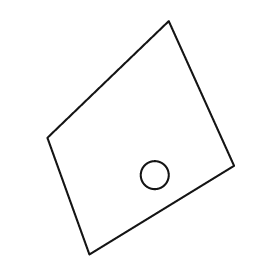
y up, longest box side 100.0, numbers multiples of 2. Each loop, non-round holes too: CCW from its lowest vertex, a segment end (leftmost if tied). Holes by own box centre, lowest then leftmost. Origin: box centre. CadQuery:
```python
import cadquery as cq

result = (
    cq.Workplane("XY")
    .moveTo(-22.0, -50.0)
    .lineTo(40.0, -12.0)
    .lineTo(12.0, 50.0)
    .lineTo(-40.0, 0.0)
    .close()
    .moveTo(6.0, -16.0)
    .circle(6.0)
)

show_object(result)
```